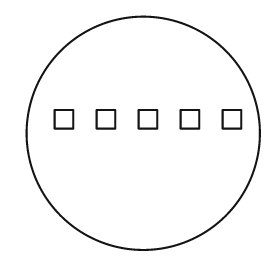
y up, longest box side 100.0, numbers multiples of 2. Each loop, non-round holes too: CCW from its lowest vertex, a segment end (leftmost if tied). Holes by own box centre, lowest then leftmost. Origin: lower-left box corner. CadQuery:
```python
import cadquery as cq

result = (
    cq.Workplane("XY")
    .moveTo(50.0, 50.0)
    .circle(50.0)
    .moveTo(12.0, 52.0)
    .lineTo(20.0, 52.0)
    .lineTo(20.0, 60.0)
    .lineTo(12.0, 60.0)
    .close()
    .moveTo(30.0, 52.0)
    .lineTo(38.0, 52.0)
    .lineTo(38.0, 60.0)
    .lineTo(30.0, 60.0)
    .close()
    .moveTo(48.0, 52.0)
    .lineTo(56.0, 52.0)
    .lineTo(56.0, 60.0)
    .lineTo(48.0, 60.0)
    .close()
    .moveTo(66.0, 52.0)
    .lineTo(74.0, 52.0)
    .lineTo(74.0, 60.0)
    .lineTo(66.0, 60.0)
    .close()
    .moveTo(84.0, 52.0)
    .lineTo(92.0, 52.0)
    .lineTo(92.0, 60.0)
    .lineTo(84.0, 60.0)
    .close()
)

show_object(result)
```